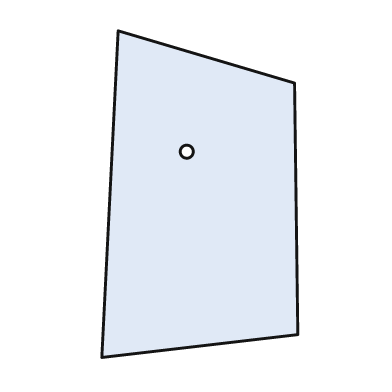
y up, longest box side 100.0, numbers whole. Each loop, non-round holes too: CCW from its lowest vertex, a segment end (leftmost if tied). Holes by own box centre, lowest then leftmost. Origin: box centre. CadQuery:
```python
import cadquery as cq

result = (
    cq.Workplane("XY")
    .moveTo(-30.0, -50.0)
    .lineTo(30.0, -43.0)
    .lineTo(29.0, 34.0)
    .lineTo(-25.0, 50.0)
    .close()
    .moveTo(-4.0, 13.0)
    .circle(2.0)
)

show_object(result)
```